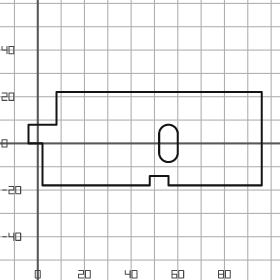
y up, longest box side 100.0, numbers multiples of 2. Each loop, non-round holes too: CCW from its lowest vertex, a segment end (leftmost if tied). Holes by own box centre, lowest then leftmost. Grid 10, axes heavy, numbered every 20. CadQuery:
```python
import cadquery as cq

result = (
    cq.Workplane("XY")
    .moveTo(2.0, -18.0)
    .lineTo(48.0, -18.0)
    .lineTo(48.0, -14.0)
    .lineTo(56.0, -14.0)
    .lineTo(56.0, -18.0)
    .lineTo(96.0, -18.0)
    .lineTo(96.0, 22.0)
    .lineTo(8.0, 22.0)
    .lineTo(8.0, 8.0)
    .lineTo(-4.0, 8.0)
    .lineTo(-4.0, 0.0)
    .lineTo(2.0, 0.0)
    .close()
    .moveTo(52.0, -4.0)
    .threePointArc((56.0, -8.0), (60.0, -4.0))
    .lineTo(60.0, 4.0)
    .threePointArc((56.0, 8.0), (52.0, 4.0))
    .close()
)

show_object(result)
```